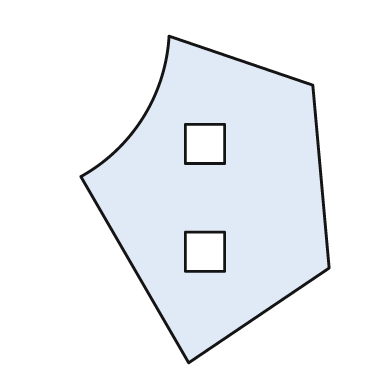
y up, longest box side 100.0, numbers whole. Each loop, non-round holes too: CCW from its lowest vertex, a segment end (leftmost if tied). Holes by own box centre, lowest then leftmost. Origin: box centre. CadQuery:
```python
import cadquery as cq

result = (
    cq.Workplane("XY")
    .moveTo(-5.0, -50.0)
    .lineTo(38.0, -21.0)
    .lineTo(33.0, 35.0)
    .lineTo(-11.0, 50.0)
    .threePointArc((-19.0, 25.0), (-38.0, 7.0))
    .close()
    .moveTo(-6.0, -22.0)
    .lineTo(6.0, -22.0)
    .lineTo(6.0, -10.0)
    .lineTo(-6.0, -10.0)
    .close()
    .moveTo(-6.0, 11.0)
    .lineTo(6.0, 11.0)
    .lineTo(6.0, 23.0)
    .lineTo(-6.0, 23.0)
    .close()
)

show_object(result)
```